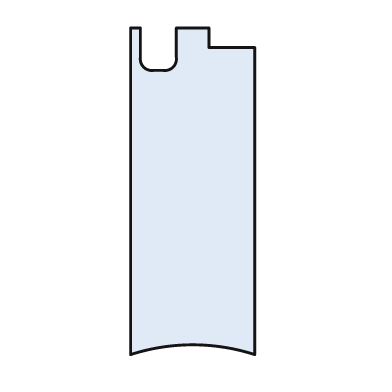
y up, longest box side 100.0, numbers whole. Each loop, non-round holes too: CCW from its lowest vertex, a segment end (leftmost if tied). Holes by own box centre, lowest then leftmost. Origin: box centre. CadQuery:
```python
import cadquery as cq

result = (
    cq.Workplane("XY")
    .moveTo(-19.0, -50.0)
    .threePointArc((0.0, -47.0), (19.0, -50.0))
    .lineTo(19.0, 44.0)
    .lineTo(5.0, 44.0)
    .lineTo(5.0, 50.0)
    .lineTo(-5.0, 50.0)
    .lineTo(-5.0, 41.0)
    .threePointArc((-6.0, 38.0), (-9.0, 37.0))
    .lineTo(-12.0, 37.0)
    .threePointArc((-15.0, 38.0), (-16.0, 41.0))
    .lineTo(-16.0, 50.0)
    .lineTo(-19.0, 50.0)
    .close()
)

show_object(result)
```